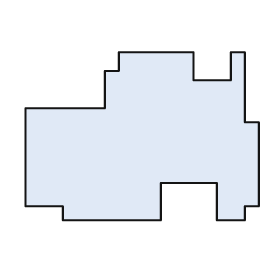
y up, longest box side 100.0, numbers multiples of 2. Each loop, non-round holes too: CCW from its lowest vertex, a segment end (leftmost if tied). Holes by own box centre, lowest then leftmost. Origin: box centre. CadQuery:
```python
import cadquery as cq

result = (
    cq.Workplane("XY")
    .moveTo(-34.0, -36.0)
    .lineTo(8.0, -36.0)
    .lineTo(8.0, -20.0)
    .lineTo(32.0, -20.0)
    .lineTo(32.0, -36.0)
    .lineTo(44.0, -36.0)
    .lineTo(44.0, -30.0)
    .lineTo(50.0, -30.0)
    .lineTo(50.0, 6.0)
    .lineTo(44.0, 6.0)
    .lineTo(44.0, 36.0)
    .lineTo(38.0, 36.0)
    .lineTo(38.0, 24.0)
    .lineTo(22.0, 24.0)
    .lineTo(22.0, 36.0)
    .lineTo(-10.0, 36.0)
    .lineTo(-10.0, 28.0)
    .lineTo(-16.0, 28.0)
    .lineTo(-16.0, 12.0)
    .lineTo(-50.0, 12.0)
    .lineTo(-50.0, -30.0)
    .lineTo(-34.0, -30.0)
    .close()
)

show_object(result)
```